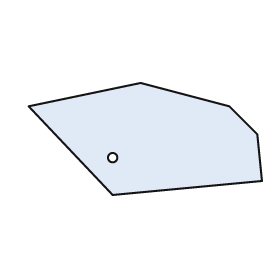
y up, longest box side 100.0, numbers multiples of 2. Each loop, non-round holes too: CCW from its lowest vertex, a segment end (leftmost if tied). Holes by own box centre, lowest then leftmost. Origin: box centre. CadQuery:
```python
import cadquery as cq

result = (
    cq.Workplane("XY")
    .moveTo(-14.0, -24.0)
    .lineTo(50.0, -18.0)
    .lineTo(48.0, 2.0)
    .lineTo(36.0, 14.0)
    .lineTo(-2.0, 24.0)
    .lineTo(-50.0, 14.0)
    .close()
    .moveTo(-14.0, -8.0)
    .circle(2.0)
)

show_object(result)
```